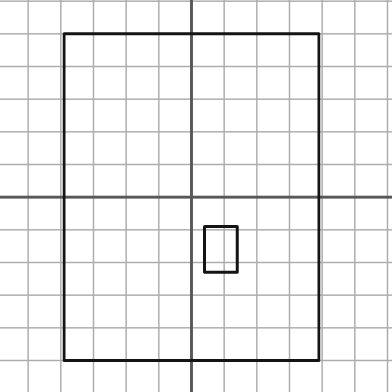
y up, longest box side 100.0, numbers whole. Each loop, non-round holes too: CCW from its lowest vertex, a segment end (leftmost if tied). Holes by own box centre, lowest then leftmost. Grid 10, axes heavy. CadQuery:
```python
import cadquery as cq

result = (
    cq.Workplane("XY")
    .moveTo(-39.0, -50.0)
    .lineTo(39.0, -50.0)
    .lineTo(39.0, 50.0)
    .lineTo(-39.0, 50.0)
    .close()
    .moveTo(4.0, -23.0)
    .lineTo(14.0, -23.0)
    .lineTo(14.0, -9.0)
    .lineTo(4.0, -9.0)
    .close()
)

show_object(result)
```